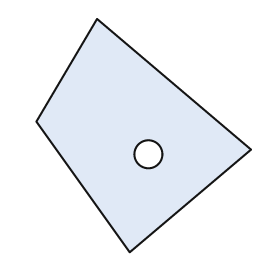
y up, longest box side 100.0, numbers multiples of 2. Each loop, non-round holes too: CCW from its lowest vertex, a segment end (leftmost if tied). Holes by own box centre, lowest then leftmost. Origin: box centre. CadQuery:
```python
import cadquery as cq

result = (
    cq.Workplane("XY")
    .moveTo(-6.0, -50.0)
    .lineTo(46.0, -6.0)
    .lineTo(-20.0, 50.0)
    .lineTo(-46.0, 6.0)
    .close()
    .moveTo(2.0, -8.0)
    .circle(6.0)
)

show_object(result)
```